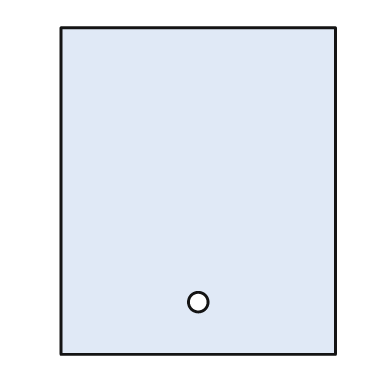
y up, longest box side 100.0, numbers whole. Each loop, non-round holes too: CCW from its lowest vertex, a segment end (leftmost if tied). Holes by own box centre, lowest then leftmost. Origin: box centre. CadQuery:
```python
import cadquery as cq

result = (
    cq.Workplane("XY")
    .moveTo(-42.0, -50.0)
    .lineTo(42.0, -50.0)
    .lineTo(42.0, 50.0)
    .lineTo(-42.0, 50.0)
    .close()
    .moveTo(0.0, -34.0)
    .circle(3.0)
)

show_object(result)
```